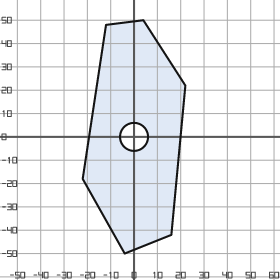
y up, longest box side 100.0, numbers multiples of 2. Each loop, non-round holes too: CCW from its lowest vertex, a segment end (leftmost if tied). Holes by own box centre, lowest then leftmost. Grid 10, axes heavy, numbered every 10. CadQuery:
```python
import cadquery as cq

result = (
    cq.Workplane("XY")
    .moveTo(-4.0, -50.0)
    .lineTo(16.0, -42.0)
    .lineTo(22.0, 22.0)
    .lineTo(4.0, 50.0)
    .lineTo(-12.0, 48.0)
    .lineTo(-22.0, -18.0)
    .close()
    .moveTo(0.0, 0.0)
    .circle(6.0)
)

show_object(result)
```